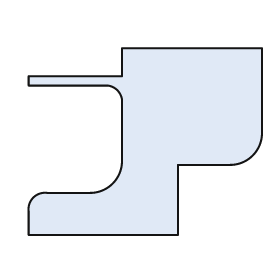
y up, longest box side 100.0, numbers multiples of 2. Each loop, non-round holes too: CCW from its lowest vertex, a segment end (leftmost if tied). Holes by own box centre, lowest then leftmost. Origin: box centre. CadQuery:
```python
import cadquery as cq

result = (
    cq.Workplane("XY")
    .moveTo(-50.0, -40.0)
    .lineTo(14.0, -40.0)
    .lineTo(14.0, -10.0)
    .lineTo(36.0, -10.0)
    .threePointArc((46.0, -6.0), (50.0, 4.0))
    .lineTo(50.0, 40.0)
    .lineTo(-10.0, 40.0)
    .lineTo(-10.0, 28.0)
    .lineTo(-50.0, 28.0)
    .lineTo(-50.0, 24.0)
    .lineTo(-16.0, 24.0)
    .threePointArc((-12.0, 22.0), (-10.0, 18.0))
    .lineTo(-10.0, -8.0)
    .threePointArc((-14.0, -18.0), (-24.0, -22.0))
    .lineTo(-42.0, -22.0)
    .threePointArc((-48.0, -24.0), (-50.0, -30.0))
    .close()
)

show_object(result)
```